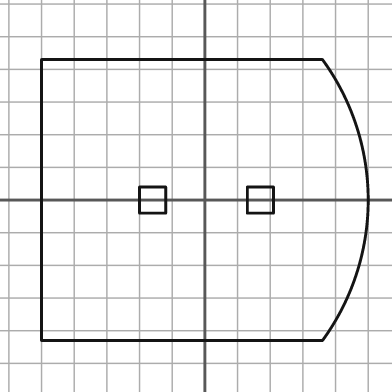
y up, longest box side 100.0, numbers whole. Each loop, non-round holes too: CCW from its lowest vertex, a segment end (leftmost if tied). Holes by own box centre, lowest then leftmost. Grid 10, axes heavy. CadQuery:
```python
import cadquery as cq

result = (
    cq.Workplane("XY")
    .moveTo(-50.0, -43.0)
    .lineTo(36.0, -43.0)
    .threePointArc((50.0, 0.0), (36.0, 43.0))
    .lineTo(-50.0, 43.0)
    .close()
    .moveTo(-20.0, -4.0)
    .lineTo(-12.0, -4.0)
    .lineTo(-12.0, 4.0)
    .lineTo(-20.0, 4.0)
    .close()
    .moveTo(13.0, -4.0)
    .lineTo(21.0, -4.0)
    .lineTo(21.0, 4.0)
    .lineTo(13.0, 4.0)
    .close()
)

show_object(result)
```